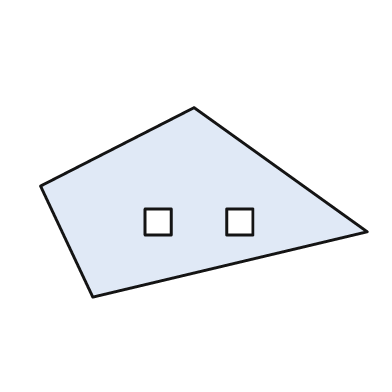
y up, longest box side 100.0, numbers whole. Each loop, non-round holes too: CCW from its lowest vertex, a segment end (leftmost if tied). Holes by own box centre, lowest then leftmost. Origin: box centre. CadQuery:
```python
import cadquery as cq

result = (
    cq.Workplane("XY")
    .moveTo(-34.0, -29.0)
    .lineTo(50.0, -9.0)
    .lineTo(-3.0, 29.0)
    .lineTo(-50.0, 5.0)
    .close()
    .moveTo(-18.0, -10.0)
    .lineTo(-10.0, -10.0)
    .lineTo(-10.0, -2.0)
    .lineTo(-18.0, -2.0)
    .close()
    .moveTo(7.0, -10.0)
    .lineTo(15.0, -10.0)
    .lineTo(15.0, -2.0)
    .lineTo(7.0, -2.0)
    .close()
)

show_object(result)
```